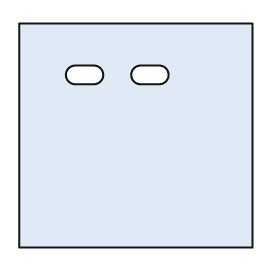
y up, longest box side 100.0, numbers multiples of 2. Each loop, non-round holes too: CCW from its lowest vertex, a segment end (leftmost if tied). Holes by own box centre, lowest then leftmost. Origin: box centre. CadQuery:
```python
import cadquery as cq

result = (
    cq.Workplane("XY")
    .moveTo(-50.0, -48.0)
    .lineTo(50.0, -48.0)
    .lineTo(50.0, 48.0)
    .lineTo(-50.0, 48.0)
    .close()
    .moveTo(-26.0, 22.0)
    .lineTo(-18.0, 22.0)
    .threePointArc((-14.0, 26.0), (-18.0, 30.0))
    .lineTo(-26.0, 30.0)
    .threePointArc((-30.0, 26.0), (-26.0, 22.0))
    .close()
    .moveTo(2.0, 22.0)
    .lineTo(10.0, 22.0)
    .threePointArc((14.0, 26.0), (10.0, 30.0))
    .lineTo(2.0, 30.0)
    .threePointArc((-2.0, 26.0), (2.0, 22.0))
    .close()
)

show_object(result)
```